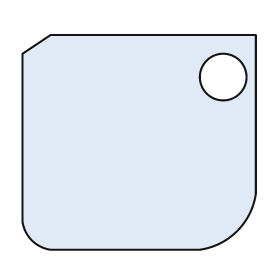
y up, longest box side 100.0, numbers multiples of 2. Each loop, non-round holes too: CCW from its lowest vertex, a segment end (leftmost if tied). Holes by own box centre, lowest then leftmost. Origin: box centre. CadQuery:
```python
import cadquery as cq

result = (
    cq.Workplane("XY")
    .moveTo(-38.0, -46.0)
    .lineTo(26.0, -46.0)
    .threePointArc((42.0, -38.0), (50.0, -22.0))
    .lineTo(50.0, 46.0)
    .lineTo(-38.0, 46.0)
    .lineTo(-50.0, 38.0)
    .lineTo(-50.0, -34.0)
    .threePointArc((-46.0, -42.0), (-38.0, -46.0))
    .close()
    .moveTo(36.0, 28.0)
    .circle(10.0)
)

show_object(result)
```